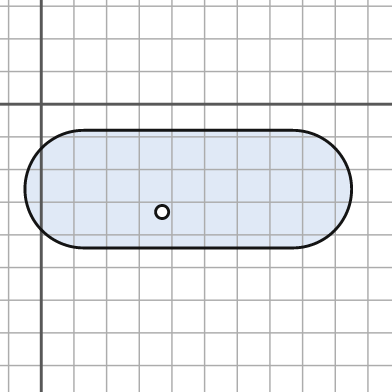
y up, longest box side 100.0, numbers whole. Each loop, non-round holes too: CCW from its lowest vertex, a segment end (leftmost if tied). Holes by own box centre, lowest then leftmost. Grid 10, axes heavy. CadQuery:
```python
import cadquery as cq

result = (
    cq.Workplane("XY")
    .moveTo(13.0, -44.0)
    .lineTo(77.0, -44.0)
    .threePointArc((95.0, -26.0), (77.0, -8.0))
    .lineTo(13.0, -8.0)
    .threePointArc((-5.0, -26.0), (13.0, -44.0))
    .close()
    .moveTo(37.0, -33.0)
    .circle(2.0)
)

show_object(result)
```